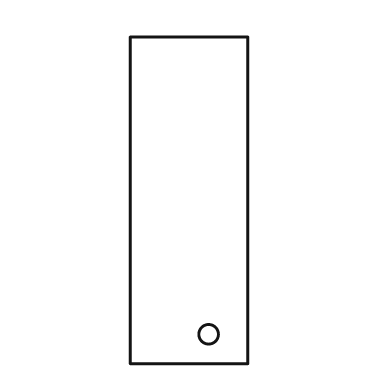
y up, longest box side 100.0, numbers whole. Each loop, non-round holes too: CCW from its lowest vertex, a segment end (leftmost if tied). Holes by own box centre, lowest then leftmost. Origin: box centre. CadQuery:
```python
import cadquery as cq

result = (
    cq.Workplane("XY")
    .moveTo(-18.0, -50.0)
    .lineTo(18.0, -50.0)
    .lineTo(18.0, 50.0)
    .lineTo(-18.0, 50.0)
    .close()
    .moveTo(6.0, -41.0)
    .circle(3.0)
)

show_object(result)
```